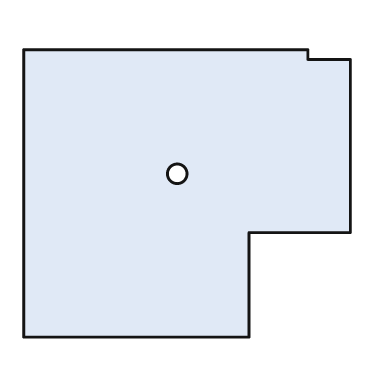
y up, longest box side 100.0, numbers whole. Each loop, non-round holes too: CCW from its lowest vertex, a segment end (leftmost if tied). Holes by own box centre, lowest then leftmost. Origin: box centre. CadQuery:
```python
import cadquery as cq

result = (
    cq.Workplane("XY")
    .moveTo(-50.0, -44.0)
    .lineTo(19.0, -44.0)
    .lineTo(19.0, -12.0)
    .lineTo(50.0, -12.0)
    .lineTo(50.0, 41.0)
    .lineTo(37.0, 41.0)
    .lineTo(37.0, 44.0)
    .lineTo(-50.0, 44.0)
    .close()
    .moveTo(-3.0, 6.0)
    .circle(3.0)
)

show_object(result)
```